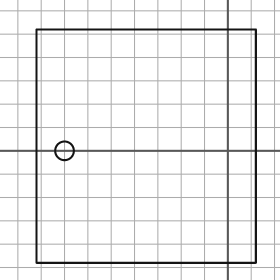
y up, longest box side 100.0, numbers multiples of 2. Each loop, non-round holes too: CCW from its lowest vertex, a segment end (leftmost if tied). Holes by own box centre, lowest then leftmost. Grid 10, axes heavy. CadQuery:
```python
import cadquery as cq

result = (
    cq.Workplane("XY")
    .moveTo(-82.0, -48.0)
    .lineTo(12.0, -48.0)
    .lineTo(12.0, 52.0)
    .lineTo(-82.0, 52.0)
    .close()
    .moveTo(-70.0, 0.0)
    .circle(4.0)
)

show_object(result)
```